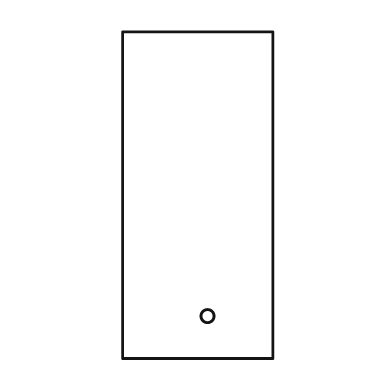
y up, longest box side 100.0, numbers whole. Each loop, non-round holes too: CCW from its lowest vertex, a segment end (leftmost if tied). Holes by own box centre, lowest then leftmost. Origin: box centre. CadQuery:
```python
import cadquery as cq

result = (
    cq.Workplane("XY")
    .moveTo(-23.0, -50.0)
    .lineTo(23.0, -50.0)
    .lineTo(23.0, 50.0)
    .lineTo(-23.0, 50.0)
    .close()
    .moveTo(3.0, -37.0)
    .circle(2.0)
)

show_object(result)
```